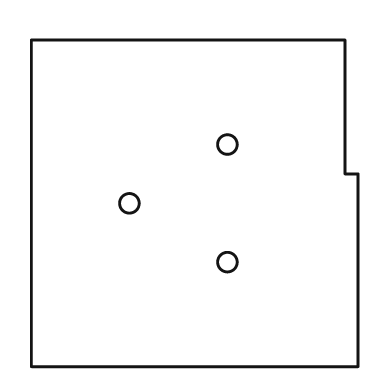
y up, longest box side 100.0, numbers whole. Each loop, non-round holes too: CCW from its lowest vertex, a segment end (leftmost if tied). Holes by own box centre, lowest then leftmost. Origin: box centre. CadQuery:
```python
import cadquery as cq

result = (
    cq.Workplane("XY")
    .moveTo(-50.0, -50.0)
    .lineTo(50.0, -50.0)
    .lineTo(50.0, 9.0)
    .lineTo(46.0, 9.0)
    .lineTo(46.0, 50.0)
    .lineTo(-50.0, 50.0)
    .close()
    .moveTo(10.0, -18.0)
    .circle(3.0)
    .moveTo(-20.0, 0.0)
    .circle(3.0)
    .moveTo(10.0, 18.0)
    .circle(3.0)
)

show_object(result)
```